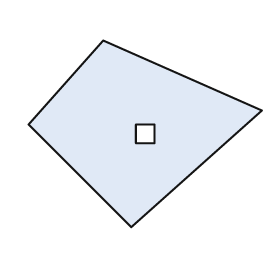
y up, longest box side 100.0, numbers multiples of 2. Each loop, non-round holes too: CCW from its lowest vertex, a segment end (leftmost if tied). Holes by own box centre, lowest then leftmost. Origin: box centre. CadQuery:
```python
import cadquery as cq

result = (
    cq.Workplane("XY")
    .moveTo(-6.0, -40.0)
    .lineTo(50.0, 10.0)
    .lineTo(-18.0, 40.0)
    .lineTo(-50.0, 4.0)
    .close()
    .moveTo(-4.0, -4.0)
    .lineTo(4.0, -4.0)
    .lineTo(4.0, 4.0)
    .lineTo(-4.0, 4.0)
    .close()
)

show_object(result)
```